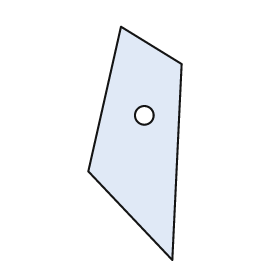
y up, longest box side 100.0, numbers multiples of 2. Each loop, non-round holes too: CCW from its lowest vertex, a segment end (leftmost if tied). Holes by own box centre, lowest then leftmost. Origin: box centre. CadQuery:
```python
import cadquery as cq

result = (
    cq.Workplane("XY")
    .moveTo(16.0, -50.0)
    .lineTo(20.0, 34.0)
    .lineTo(-6.0, 50.0)
    .lineTo(-20.0, -12.0)
    .close()
    .moveTo(4.0, 12.0)
    .circle(4.0)
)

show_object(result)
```